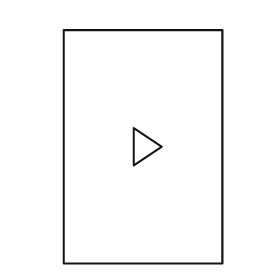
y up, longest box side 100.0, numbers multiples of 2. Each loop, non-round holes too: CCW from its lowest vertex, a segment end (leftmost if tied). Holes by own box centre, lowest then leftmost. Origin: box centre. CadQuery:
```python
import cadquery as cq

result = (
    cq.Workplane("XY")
    .moveTo(-34.0, -50.0)
    .lineTo(34.0, -50.0)
    .lineTo(34.0, 50.0)
    .lineTo(-34.0, 50.0)
    .close()
    .moveTo(-4.0, -8.0)
    .lineTo(8.0, 0.0)
    .lineTo(-4.0, 8.0)
    .close()
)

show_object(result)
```